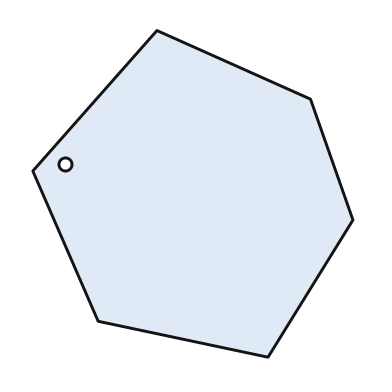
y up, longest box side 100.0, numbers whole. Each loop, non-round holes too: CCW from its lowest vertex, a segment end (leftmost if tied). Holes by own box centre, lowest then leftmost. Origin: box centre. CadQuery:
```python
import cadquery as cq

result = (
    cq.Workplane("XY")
    .moveTo(23.0, -50.0)
    .lineTo(49.0, -8.0)
    .lineTo(36.0, 29.0)
    .lineTo(-11.0, 50.0)
    .lineTo(-49.0, 7.0)
    .lineTo(-29.0, -39.0)
    .close()
    .moveTo(-39.0, 9.0)
    .circle(2.0)
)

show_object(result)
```